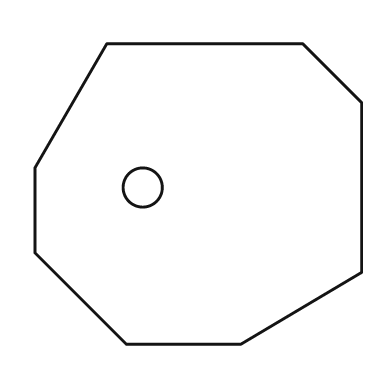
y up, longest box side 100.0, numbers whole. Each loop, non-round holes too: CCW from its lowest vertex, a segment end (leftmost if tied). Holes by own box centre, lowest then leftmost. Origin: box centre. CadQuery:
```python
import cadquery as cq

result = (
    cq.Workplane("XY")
    .moveTo(-22.0, -46.0)
    .lineTo(13.0, -46.0)
    .lineTo(50.0, -24.0)
    .lineTo(50.0, 28.0)
    .lineTo(32.0, 46.0)
    .lineTo(-28.0, 46.0)
    .lineTo(-50.0, 8.0)
    .lineTo(-50.0, -18.0)
    .close()
    .moveTo(-17.0, 2.0)
    .circle(6.0)
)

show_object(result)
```